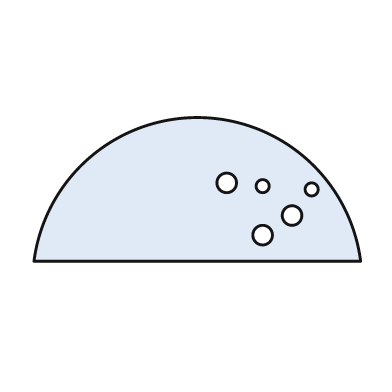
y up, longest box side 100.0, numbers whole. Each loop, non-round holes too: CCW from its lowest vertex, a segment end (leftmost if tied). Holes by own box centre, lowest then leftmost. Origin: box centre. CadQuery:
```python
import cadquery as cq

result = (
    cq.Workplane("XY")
    .moveTo(-50.0, -22.0)
    .lineTo(50.0, -22.0)
    .threePointArc((0.0, 22.0), (-50.0, -22.0))
    .close()
    .moveTo(20.0, -14.0)
    .circle(3.0)
    .moveTo(29.0, -8.0)
    .circle(3.0)
    .moveTo(35.0, 0.0)
    .circle(2.0)
    .moveTo(20.0, 1.0)
    .circle(2.0)
    .moveTo(9.0, 2.0)
    .circle(3.0)
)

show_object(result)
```